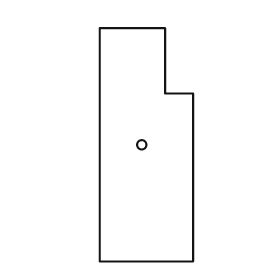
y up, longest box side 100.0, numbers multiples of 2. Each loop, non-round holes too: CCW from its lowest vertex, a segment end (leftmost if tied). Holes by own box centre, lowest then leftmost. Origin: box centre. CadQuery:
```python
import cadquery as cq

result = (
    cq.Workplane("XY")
    .moveTo(-20.0, -50.0)
    .lineTo(20.0, -50.0)
    .lineTo(20.0, 22.0)
    .lineTo(8.0, 22.0)
    .lineTo(8.0, 50.0)
    .lineTo(-20.0, 50.0)
    .close()
    .moveTo(-2.0, 0.0)
    .circle(2.0)
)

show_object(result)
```